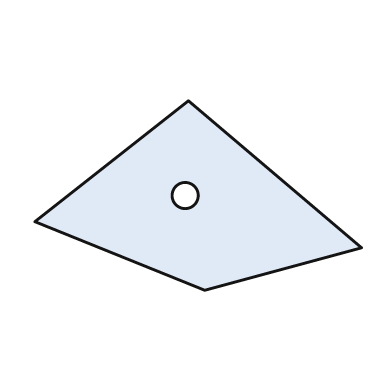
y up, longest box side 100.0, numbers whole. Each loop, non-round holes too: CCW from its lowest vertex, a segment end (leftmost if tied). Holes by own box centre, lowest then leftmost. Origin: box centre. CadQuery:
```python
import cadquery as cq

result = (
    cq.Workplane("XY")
    .moveTo(2.0, -29.0)
    .lineTo(50.0, -16.0)
    .lineTo(-3.0, 29.0)
    .lineTo(-50.0, -8.0)
    .close()
    .moveTo(-4.0, 0.0)
    .circle(4.0)
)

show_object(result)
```